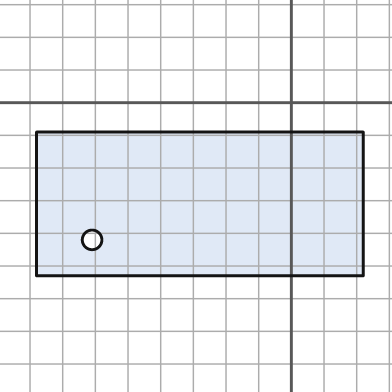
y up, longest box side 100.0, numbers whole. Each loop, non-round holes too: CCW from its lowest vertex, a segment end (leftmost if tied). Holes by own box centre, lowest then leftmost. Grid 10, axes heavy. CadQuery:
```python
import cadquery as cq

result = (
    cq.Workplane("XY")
    .moveTo(-78.0, -53.0)
    .lineTo(22.0, -53.0)
    .lineTo(22.0, -9.0)
    .lineTo(-78.0, -9.0)
    .close()
    .moveTo(-61.0, -42.0)
    .circle(3.0)
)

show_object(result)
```